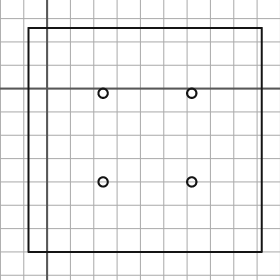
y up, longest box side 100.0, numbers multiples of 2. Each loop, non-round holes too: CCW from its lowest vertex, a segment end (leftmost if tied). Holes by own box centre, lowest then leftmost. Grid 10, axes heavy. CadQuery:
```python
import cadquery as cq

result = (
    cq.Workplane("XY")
    .moveTo(-8.0, -70.0)
    .lineTo(92.0, -70.0)
    .lineTo(92.0, 26.0)
    .lineTo(-8.0, 26.0)
    .close()
    .moveTo(24.0, -40.0)
    .circle(2.0)
    .moveTo(62.0, -40.0)
    .circle(2.0)
    .moveTo(24.0, -2.0)
    .circle(2.0)
    .moveTo(62.0, -2.0)
    .circle(2.0)
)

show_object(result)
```